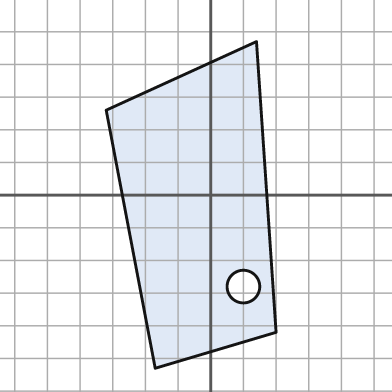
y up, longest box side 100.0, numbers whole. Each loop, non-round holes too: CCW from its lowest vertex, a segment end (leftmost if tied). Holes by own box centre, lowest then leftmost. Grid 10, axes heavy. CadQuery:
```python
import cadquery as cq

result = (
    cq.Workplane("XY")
    .moveTo(-17.0, -53.0)
    .lineTo(20.0, -42.0)
    .lineTo(14.0, 47.0)
    .lineTo(-32.0, 26.0)
    .close()
    .moveTo(10.0, -28.0)
    .circle(5.0)
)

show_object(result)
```